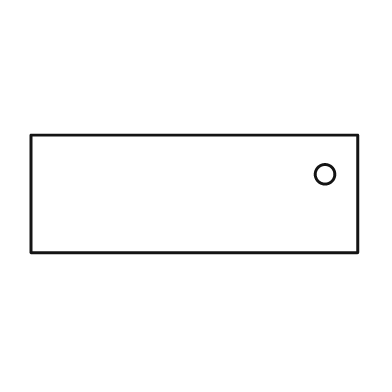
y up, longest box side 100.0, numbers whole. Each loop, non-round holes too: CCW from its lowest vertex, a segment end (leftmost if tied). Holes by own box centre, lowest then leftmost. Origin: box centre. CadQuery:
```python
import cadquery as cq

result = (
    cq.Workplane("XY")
    .moveTo(-50.0, -18.0)
    .lineTo(50.0, -18.0)
    .lineTo(50.0, 18.0)
    .lineTo(-50.0, 18.0)
    .close()
    .moveTo(40.0, 6.0)
    .circle(3.0)
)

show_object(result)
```